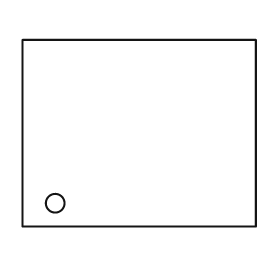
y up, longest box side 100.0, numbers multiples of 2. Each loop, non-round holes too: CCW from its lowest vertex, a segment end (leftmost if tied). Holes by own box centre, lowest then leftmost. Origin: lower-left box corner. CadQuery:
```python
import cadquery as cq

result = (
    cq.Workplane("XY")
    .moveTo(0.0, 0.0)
    .lineTo(100.0, 0.0)
    .lineTo(100.0, 80.0)
    .lineTo(0.0, 80.0)
    .close()
    .moveTo(14.0, 10.0)
    .circle(4.0)
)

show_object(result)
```